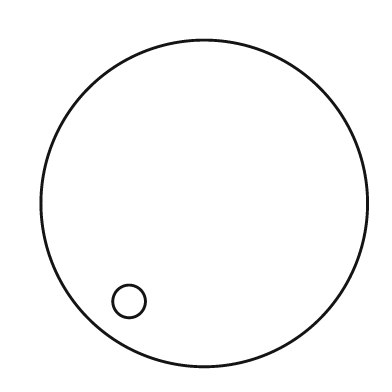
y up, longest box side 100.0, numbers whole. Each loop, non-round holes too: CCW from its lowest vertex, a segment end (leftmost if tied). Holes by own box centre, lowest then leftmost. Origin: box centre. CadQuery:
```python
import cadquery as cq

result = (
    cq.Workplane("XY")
    .moveTo(0.0, 0.0)
    .circle(50.0)
    .moveTo(-23.0, -30.0)
    .circle(5.0)
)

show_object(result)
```